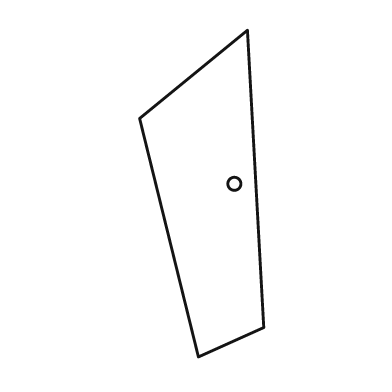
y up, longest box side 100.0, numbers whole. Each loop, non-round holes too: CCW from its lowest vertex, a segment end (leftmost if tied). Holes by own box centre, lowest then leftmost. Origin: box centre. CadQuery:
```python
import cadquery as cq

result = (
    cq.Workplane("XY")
    .moveTo(-1.0, -50.0)
    .lineTo(19.0, -41.0)
    .lineTo(14.0, 50.0)
    .lineTo(-19.0, 23.0)
    .close()
    .moveTo(10.0, 3.0)
    .circle(2.0)
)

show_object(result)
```